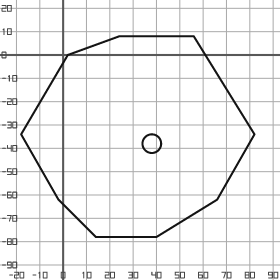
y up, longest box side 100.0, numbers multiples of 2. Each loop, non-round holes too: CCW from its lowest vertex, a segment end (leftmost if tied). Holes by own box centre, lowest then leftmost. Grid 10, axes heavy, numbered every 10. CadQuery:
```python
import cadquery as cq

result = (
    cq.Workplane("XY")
    .moveTo(14.0, -78.0)
    .lineTo(40.0, -78.0)
    .lineTo(66.0, -62.0)
    .lineTo(82.0, -34.0)
    .lineTo(56.0, 8.0)
    .lineTo(24.0, 8.0)
    .lineTo(2.0, 0.0)
    .lineTo(-18.0, -34.0)
    .lineTo(-2.0, -62.0)
    .close()
    .moveTo(38.0, -38.0)
    .circle(4.0)
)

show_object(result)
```